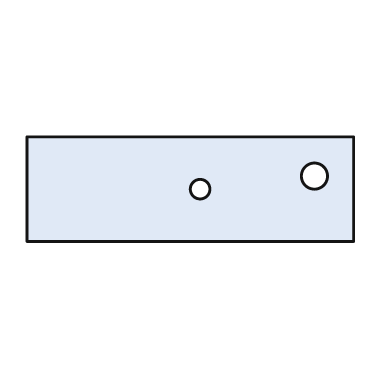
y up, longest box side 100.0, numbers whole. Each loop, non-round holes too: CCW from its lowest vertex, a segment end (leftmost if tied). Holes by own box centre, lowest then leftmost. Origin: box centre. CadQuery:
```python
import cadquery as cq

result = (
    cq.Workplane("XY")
    .moveTo(-50.0, -16.0)
    .lineTo(50.0, -16.0)
    .lineTo(50.0, 16.0)
    .lineTo(-50.0, 16.0)
    .close()
    .moveTo(3.0, 0.0)
    .circle(3.0)
    .moveTo(38.0, 4.0)
    .circle(4.0)
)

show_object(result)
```